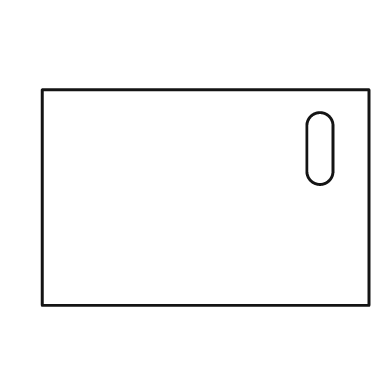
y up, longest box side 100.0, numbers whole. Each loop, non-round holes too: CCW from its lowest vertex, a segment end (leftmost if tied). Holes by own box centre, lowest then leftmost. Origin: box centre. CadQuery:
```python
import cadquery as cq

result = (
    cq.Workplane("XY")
    .moveTo(-50.0, -33.0)
    .lineTo(50.0, -33.0)
    .lineTo(50.0, 33.0)
    .lineTo(-50.0, 33.0)
    .close()
    .moveTo(31.0, 8.0)
    .threePointArc((35.0, 4.0), (39.0, 8.0))
    .lineTo(39.0, 22.0)
    .threePointArc((35.0, 26.0), (31.0, 22.0))
    .close()
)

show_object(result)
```